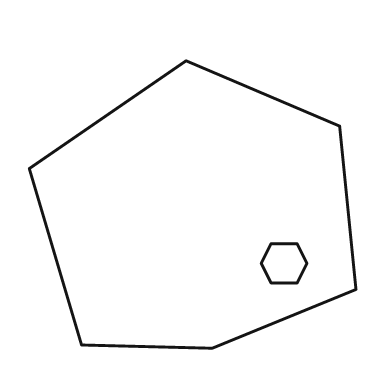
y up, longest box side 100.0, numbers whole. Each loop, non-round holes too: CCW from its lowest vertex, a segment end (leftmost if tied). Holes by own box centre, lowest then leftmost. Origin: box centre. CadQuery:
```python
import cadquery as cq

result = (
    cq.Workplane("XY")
    .moveTo(6.0, -44.0)
    .lineTo(50.0, -26.0)
    .lineTo(45.0, 24.0)
    .lineTo(-2.0, 44.0)
    .lineTo(-50.0, 11.0)
    .lineTo(-34.0, -43.0)
    .close()
    .moveTo(24.0, -24.0)
    .lineTo(32.0, -24.0)
    .lineTo(35.0, -18.0)
    .lineTo(32.0, -12.0)
    .lineTo(24.0, -12.0)
    .lineTo(21.0, -18.0)
    .close()
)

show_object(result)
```